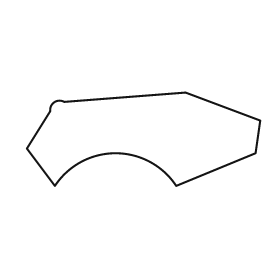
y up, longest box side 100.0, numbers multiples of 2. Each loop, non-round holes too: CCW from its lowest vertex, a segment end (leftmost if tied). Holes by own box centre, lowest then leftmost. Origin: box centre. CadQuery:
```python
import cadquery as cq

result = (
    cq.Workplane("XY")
    .moveTo(-38.0, -20.0)
    .threePointArc((-12.0, -6.0), (14.0, -20.0))
    .lineTo(48.0, -6.0)
    .lineTo(50.0, 8.0)
    .lineTo(18.0, 20.0)
    .lineTo(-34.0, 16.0)
    .threePointArc((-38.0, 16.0), (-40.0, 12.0))
    .lineTo(-50.0, -4.0)
    .close()
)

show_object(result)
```